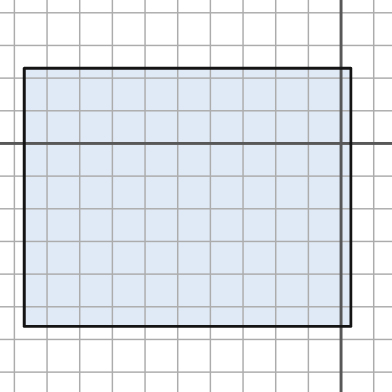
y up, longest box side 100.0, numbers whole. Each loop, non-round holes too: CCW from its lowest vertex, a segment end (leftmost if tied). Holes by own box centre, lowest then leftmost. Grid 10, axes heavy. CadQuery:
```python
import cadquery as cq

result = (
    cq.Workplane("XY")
    .moveTo(-97.0, -56.0)
    .lineTo(3.0, -56.0)
    .lineTo(3.0, 23.0)
    .lineTo(-97.0, 23.0)
    .close()
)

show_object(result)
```